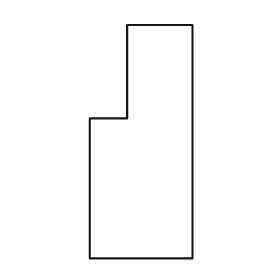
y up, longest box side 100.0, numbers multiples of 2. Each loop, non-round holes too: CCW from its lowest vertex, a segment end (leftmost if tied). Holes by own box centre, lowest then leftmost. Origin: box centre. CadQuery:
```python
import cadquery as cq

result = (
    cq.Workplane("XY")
    .moveTo(-22.0, -50.0)
    .lineTo(22.0, -50.0)
    .lineTo(22.0, 50.0)
    .lineTo(-6.0, 50.0)
    .lineTo(-6.0, 10.0)
    .lineTo(-22.0, 10.0)
    .close()
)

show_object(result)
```